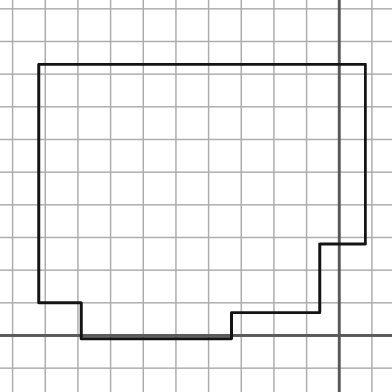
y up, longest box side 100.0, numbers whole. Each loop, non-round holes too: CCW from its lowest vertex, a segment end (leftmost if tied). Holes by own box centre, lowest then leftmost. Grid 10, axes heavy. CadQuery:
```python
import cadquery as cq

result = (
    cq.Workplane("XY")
    .moveTo(-79.0, -1.0)
    .lineTo(-33.0, -1.0)
    .lineTo(-33.0, 7.0)
    .lineTo(-6.0, 7.0)
    .lineTo(-6.0, 28.0)
    .lineTo(8.0, 28.0)
    .lineTo(8.0, 83.0)
    .lineTo(-92.0, 83.0)
    .lineTo(-92.0, 10.0)
    .lineTo(-79.0, 10.0)
    .close()
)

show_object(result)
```